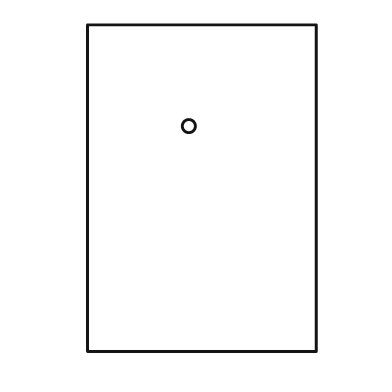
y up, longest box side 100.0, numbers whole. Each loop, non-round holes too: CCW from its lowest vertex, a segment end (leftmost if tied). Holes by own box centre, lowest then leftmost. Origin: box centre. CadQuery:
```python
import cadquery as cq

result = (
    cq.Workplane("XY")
    .moveTo(-35.0, -50.0)
    .lineTo(35.0, -50.0)
    .lineTo(35.0, 50.0)
    .lineTo(-35.0, 50.0)
    .close()
    .moveTo(-4.0, 19.0)
    .circle(2.0)
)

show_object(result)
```